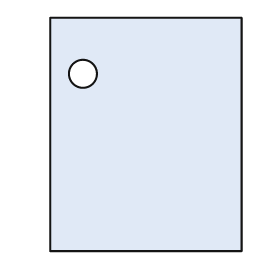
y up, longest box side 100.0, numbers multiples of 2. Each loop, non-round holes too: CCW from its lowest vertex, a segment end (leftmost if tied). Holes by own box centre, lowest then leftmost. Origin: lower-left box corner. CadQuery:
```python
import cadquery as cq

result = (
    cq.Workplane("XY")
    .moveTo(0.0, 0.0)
    .lineTo(82.0, 0.0)
    .lineTo(82.0, 100.0)
    .lineTo(0.0, 100.0)
    .close()
    .moveTo(14.0, 76.0)
    .circle(6.0)
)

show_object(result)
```